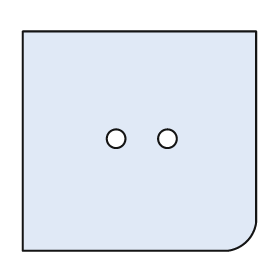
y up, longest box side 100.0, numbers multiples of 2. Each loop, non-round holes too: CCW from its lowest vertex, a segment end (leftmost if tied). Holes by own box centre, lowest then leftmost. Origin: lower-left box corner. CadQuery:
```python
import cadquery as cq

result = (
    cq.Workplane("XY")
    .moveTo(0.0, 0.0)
    .lineTo(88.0, 0.0)
    .threePointArc((96.0, 4.0), (100.0, 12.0))
    .lineTo(100.0, 94.0)
    .lineTo(0.0, 94.0)
    .close()
    .moveTo(40.0, 48.0)
    .circle(4.0)
    .moveTo(62.0, 48.0)
    .circle(4.0)
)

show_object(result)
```